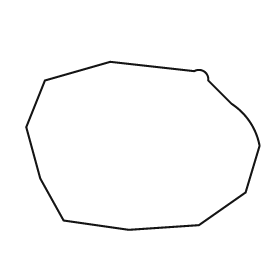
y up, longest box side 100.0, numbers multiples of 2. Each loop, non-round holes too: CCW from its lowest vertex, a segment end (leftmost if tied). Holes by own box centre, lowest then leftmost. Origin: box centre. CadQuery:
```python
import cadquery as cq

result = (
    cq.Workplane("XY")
    .moveTo(-6.0, -36.0)
    .lineTo(24.0, -34.0)
    .lineTo(44.0, -20.0)
    .lineTo(50.0, 0.0)
    .threePointArc((46.0, 10.0), (38.0, 18.0))
    .lineTo(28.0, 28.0)
    .threePointArc((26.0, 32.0), (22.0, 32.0))
    .lineTo(-14.0, 36.0)
    .lineTo(-42.0, 28.0)
    .lineTo(-50.0, 8.0)
    .lineTo(-44.0, -14.0)
    .lineTo(-34.0, -32.0)
    .close()
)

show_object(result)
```